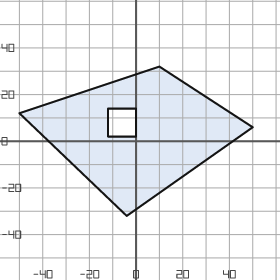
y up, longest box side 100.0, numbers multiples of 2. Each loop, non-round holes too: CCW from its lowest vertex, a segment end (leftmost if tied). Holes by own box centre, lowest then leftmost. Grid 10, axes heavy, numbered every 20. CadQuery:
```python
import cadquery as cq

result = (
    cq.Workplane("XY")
    .moveTo(-4.0, -32.0)
    .lineTo(50.0, 6.0)
    .lineTo(10.0, 32.0)
    .lineTo(-50.0, 12.0)
    .close()
    .moveTo(-12.0, 2.0)
    .lineTo(0.0, 2.0)
    .lineTo(0.0, 14.0)
    .lineTo(-12.0, 14.0)
    .close()
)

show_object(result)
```